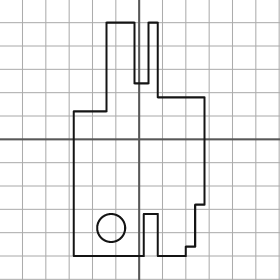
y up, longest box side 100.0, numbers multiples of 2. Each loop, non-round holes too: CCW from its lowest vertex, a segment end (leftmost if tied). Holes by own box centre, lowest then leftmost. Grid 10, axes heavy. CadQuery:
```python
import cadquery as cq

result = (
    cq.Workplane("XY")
    .moveTo(-28.0, -50.0)
    .lineTo(2.0, -50.0)
    .lineTo(2.0, -32.0)
    .lineTo(8.0, -32.0)
    .lineTo(8.0, -50.0)
    .lineTo(20.0, -50.0)
    .lineTo(20.0, -46.0)
    .lineTo(24.0, -46.0)
    .lineTo(24.0, -28.0)
    .lineTo(28.0, -28.0)
    .lineTo(28.0, 18.0)
    .lineTo(8.0, 18.0)
    .lineTo(8.0, 50.0)
    .lineTo(4.0, 50.0)
    .lineTo(4.0, 24.0)
    .lineTo(-2.0, 24.0)
    .lineTo(-2.0, 50.0)
    .lineTo(-14.0, 50.0)
    .lineTo(-14.0, 12.0)
    .lineTo(-28.0, 12.0)
    .close()
    .moveTo(-12.0, -38.0)
    .circle(6.0)
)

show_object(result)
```